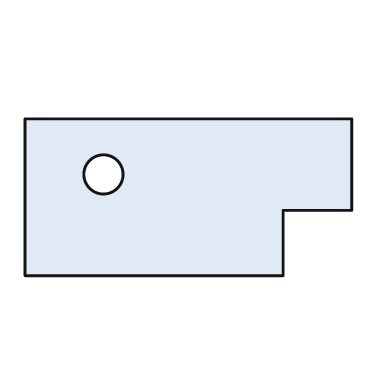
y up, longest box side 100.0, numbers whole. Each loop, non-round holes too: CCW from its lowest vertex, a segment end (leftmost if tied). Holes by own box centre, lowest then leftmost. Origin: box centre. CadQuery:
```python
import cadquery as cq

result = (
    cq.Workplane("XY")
    .moveTo(-50.0, -24.0)
    .lineTo(29.0, -24.0)
    .lineTo(29.0, -4.0)
    .lineTo(50.0, -4.0)
    .lineTo(50.0, 24.0)
    .lineTo(-50.0, 24.0)
    .close()
    .moveTo(-26.0, 7.0)
    .circle(6.0)
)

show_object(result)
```